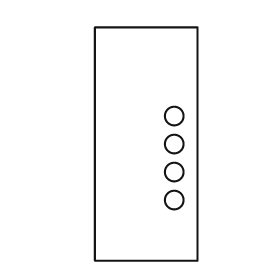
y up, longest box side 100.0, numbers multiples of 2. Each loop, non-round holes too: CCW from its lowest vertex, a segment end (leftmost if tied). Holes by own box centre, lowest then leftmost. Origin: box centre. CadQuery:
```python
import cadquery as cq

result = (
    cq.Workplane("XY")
    .moveTo(-22.0, -50.0)
    .lineTo(22.0, -50.0)
    .lineTo(22.0, 50.0)
    .lineTo(-22.0, 50.0)
    .close()
    .moveTo(12.0, -24.0)
    .circle(4.0)
    .moveTo(12.0, -12.0)
    .circle(4.0)
    .moveTo(12.0, 0.0)
    .circle(4.0)
    .moveTo(12.0, 12.0)
    .circle(4.0)
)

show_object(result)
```